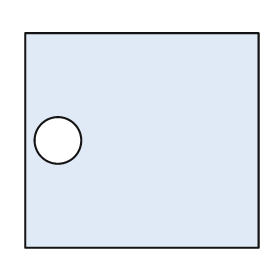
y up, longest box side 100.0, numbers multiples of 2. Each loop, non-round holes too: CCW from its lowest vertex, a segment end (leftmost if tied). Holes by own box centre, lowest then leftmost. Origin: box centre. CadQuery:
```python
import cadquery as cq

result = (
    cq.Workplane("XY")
    .moveTo(-50.0, -46.0)
    .lineTo(50.0, -46.0)
    .lineTo(50.0, 46.0)
    .lineTo(-50.0, 46.0)
    .close()
    .moveTo(-36.0, 0.0)
    .circle(10.0)
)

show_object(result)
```